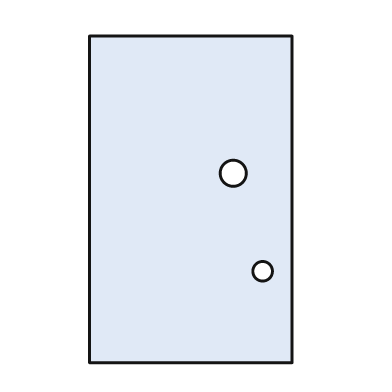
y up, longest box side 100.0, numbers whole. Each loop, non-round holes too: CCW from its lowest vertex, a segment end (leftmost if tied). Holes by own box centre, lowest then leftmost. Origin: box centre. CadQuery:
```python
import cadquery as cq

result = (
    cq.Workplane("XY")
    .moveTo(-31.0, -50.0)
    .lineTo(31.0, -50.0)
    .lineTo(31.0, 50.0)
    .lineTo(-31.0, 50.0)
    .close()
    .moveTo(22.0, -22.0)
    .circle(3.0)
    .moveTo(13.0, 8.0)
    .circle(4.0)
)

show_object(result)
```